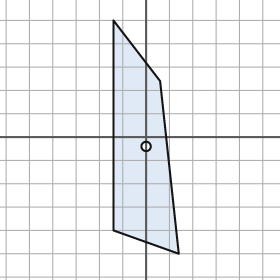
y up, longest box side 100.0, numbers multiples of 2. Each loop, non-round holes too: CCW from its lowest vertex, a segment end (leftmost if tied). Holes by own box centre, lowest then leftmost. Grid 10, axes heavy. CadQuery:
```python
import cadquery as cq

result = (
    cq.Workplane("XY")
    .moveTo(14.0, -50.0)
    .lineTo(6.0, 24.0)
    .lineTo(-14.0, 50.0)
    .lineTo(-14.0, -40.0)
    .close()
    .moveTo(0.0, -4.0)
    .circle(2.0)
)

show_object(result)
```